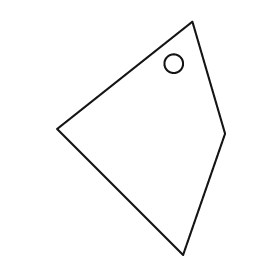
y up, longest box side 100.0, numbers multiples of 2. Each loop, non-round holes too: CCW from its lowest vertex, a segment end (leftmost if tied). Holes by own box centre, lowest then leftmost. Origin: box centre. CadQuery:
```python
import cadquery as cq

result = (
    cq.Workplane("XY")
    .moveTo(18.0, -50.0)
    .lineTo(36.0, 2.0)
    .lineTo(22.0, 50.0)
    .lineTo(-36.0, 4.0)
    .close()
    .moveTo(14.0, 32.0)
    .circle(4.0)
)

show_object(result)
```